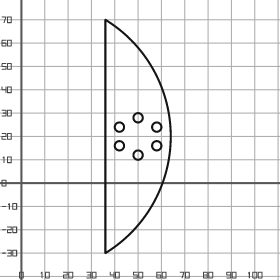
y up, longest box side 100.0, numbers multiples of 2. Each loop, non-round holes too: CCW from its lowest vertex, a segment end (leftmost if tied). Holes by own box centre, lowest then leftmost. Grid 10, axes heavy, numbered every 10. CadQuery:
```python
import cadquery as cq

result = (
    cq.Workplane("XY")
    .moveTo(36.0, -30.0)
    .threePointArc((64.0, 20.0), (36.0, 70.0))
    .close()
    .moveTo(50.0, 12.0)
    .circle(2.0)
    .moveTo(42.0, 16.0)
    .circle(2.0)
    .moveTo(58.0, 16.0)
    .circle(2.0)
    .moveTo(42.0, 24.0)
    .circle(2.0)
    .moveTo(58.0, 24.0)
    .circle(2.0)
    .moveTo(50.0, 28.0)
    .circle(2.0)
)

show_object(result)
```